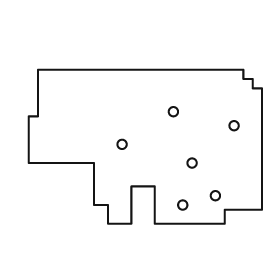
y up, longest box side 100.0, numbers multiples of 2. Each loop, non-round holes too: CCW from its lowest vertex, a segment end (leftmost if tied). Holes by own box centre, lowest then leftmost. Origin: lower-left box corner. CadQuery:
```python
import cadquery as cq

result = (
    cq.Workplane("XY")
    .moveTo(34.0, 0.0)
    .lineTo(44.0, 0.0)
    .lineTo(44.0, 16.0)
    .lineTo(54.0, 16.0)
    .lineTo(54.0, 0.0)
    .lineTo(84.0, 0.0)
    .lineTo(84.0, 6.0)
    .lineTo(100.0, 6.0)
    .lineTo(100.0, 58.0)
    .lineTo(96.0, 58.0)
    .lineTo(96.0, 62.0)
    .lineTo(92.0, 62.0)
    .lineTo(92.0, 66.0)
    .lineTo(4.0, 66.0)
    .lineTo(4.0, 46.0)
    .lineTo(0.0, 46.0)
    .lineTo(0.0, 26.0)
    .lineTo(28.0, 26.0)
    .lineTo(28.0, 8.0)
    .lineTo(34.0, 8.0)
    .close()
    .moveTo(66.0, 8.0)
    .circle(2.0)
    .moveTo(80.0, 12.0)
    .circle(2.0)
    .moveTo(70.0, 26.0)
    .circle(2.0)
    .moveTo(40.0, 34.0)
    .circle(2.0)
    .moveTo(88.0, 42.0)
    .circle(2.0)
    .moveTo(62.0, 48.0)
    .circle(2.0)
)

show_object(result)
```